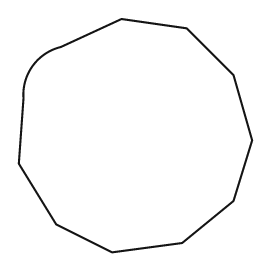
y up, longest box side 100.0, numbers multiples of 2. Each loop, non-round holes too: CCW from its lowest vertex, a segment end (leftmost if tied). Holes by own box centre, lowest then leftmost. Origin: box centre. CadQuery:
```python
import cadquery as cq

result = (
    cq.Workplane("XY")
    .moveTo(-10.0, -50.0)
    .lineTo(20.0, -46.0)
    .lineTo(42.0, -28.0)
    .lineTo(50.0, -2.0)
    .lineTo(42.0, 26.0)
    .lineTo(22.0, 46.0)
    .lineTo(-6.0, 50.0)
    .lineTo(-32.0, 38.0)
    .threePointArc((-44.0, 30.0), (-48.0, 16.0))
    .lineTo(-50.0, -12.0)
    .lineTo(-34.0, -38.0)
    .close()
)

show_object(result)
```